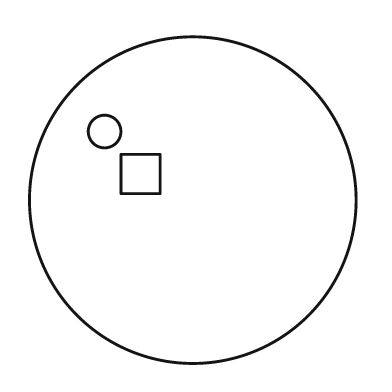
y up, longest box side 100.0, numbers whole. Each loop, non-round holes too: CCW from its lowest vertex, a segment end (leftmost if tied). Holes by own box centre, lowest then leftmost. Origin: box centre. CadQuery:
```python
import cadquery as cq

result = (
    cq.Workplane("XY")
    .moveTo(0.0, 0.0)
    .circle(50.0)
    .moveTo(-22.0, 2.0)
    .lineTo(-10.0, 2.0)
    .lineTo(-10.0, 14.0)
    .lineTo(-22.0, 14.0)
    .close()
    .moveTo(-27.0, 21.0)
    .circle(5.0)
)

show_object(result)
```